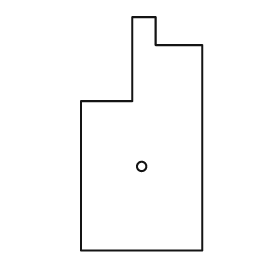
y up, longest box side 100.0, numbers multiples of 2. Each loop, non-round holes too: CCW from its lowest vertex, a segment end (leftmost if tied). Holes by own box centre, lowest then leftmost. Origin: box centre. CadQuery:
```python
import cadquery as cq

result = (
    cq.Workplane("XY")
    .moveTo(-26.0, -50.0)
    .lineTo(26.0, -50.0)
    .lineTo(26.0, 38.0)
    .lineTo(6.0, 38.0)
    .lineTo(6.0, 50.0)
    .lineTo(-4.0, 50.0)
    .lineTo(-4.0, 14.0)
    .lineTo(-26.0, 14.0)
    .close()
    .moveTo(0.0, -14.0)
    .circle(2.0)
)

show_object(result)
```